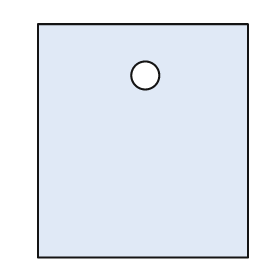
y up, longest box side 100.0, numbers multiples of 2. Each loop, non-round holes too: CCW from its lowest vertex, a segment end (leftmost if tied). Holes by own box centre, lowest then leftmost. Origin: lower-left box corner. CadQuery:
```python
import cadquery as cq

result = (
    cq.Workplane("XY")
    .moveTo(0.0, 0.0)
    .lineTo(90.0, 0.0)
    .lineTo(90.0, 100.0)
    .lineTo(0.0, 100.0)
    .close()
    .moveTo(46.0, 78.0)
    .circle(6.0)
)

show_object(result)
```